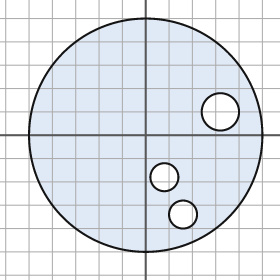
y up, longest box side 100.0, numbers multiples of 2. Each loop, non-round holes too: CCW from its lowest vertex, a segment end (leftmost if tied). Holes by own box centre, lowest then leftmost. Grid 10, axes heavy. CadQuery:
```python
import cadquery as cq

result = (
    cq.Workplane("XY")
    .moveTo(0.0, 0.0)
    .circle(50.0)
    .moveTo(16.0, -34.0)
    .circle(6.0)
    .moveTo(8.0, -18.0)
    .circle(6.0)
    .moveTo(32.0, 10.0)
    .circle(8.0)
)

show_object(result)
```